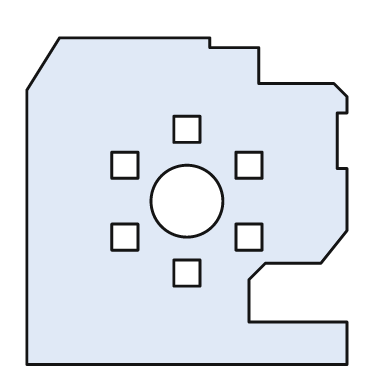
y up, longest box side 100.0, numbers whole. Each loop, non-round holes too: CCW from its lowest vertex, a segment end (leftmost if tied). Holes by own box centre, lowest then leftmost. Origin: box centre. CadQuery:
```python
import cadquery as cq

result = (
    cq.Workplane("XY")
    .moveTo(-49.0, -50.0)
    .lineTo(49.0, -50.0)
    .lineTo(49.0, -37.0)
    .lineTo(19.0, -37.0)
    .lineTo(19.0, -24.0)
    .lineTo(24.0, -19.0)
    .lineTo(41.0, -19.0)
    .lineTo(49.0, -9.0)
    .lineTo(49.0, 10.0)
    .lineTo(46.0, 10.0)
    .lineTo(46.0, 27.0)
    .lineTo(49.0, 27.0)
    .lineTo(49.0, 32.0)
    .lineTo(45.0, 36.0)
    .lineTo(22.0, 36.0)
    .lineTo(22.0, 47.0)
    .lineTo(7.0, 47.0)
    .lineTo(7.0, 50.0)
    .lineTo(-39.0, 50.0)
    .lineTo(-49.0, 34.0)
    .close()
    .moveTo(-4.0, -26.0)
    .lineTo(4.0, -26.0)
    .lineTo(4.0, -18.0)
    .lineTo(-4.0, -18.0)
    .close()
    .moveTo(-23.0, -15.0)
    .lineTo(-15.0, -15.0)
    .lineTo(-15.0, -7.0)
    .lineTo(-23.0, -7.0)
    .close()
    .moveTo(15.0, -15.0)
    .lineTo(23.0, -15.0)
    .lineTo(23.0, -7.0)
    .lineTo(15.0, -7.0)
    .close()
    .moveTo(0.0, 0.0)
    .circle(11.0)
    .moveTo(-23.0, 7.0)
    .lineTo(-15.0, 7.0)
    .lineTo(-15.0, 15.0)
    .lineTo(-23.0, 15.0)
    .close()
    .moveTo(15.0, 7.0)
    .lineTo(23.0, 7.0)
    .lineTo(23.0, 15.0)
    .lineTo(15.0, 15.0)
    .close()
    .moveTo(-4.0, 18.0)
    .lineTo(4.0, 18.0)
    .lineTo(4.0, 26.0)
    .lineTo(-4.0, 26.0)
    .close()
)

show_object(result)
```